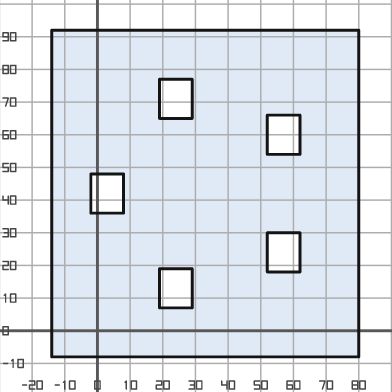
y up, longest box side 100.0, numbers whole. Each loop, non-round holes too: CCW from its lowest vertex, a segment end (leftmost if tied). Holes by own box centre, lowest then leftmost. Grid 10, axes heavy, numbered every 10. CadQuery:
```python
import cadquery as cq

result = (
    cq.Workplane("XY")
    .moveTo(-14.0, -8.0)
    .lineTo(80.0, -8.0)
    .lineTo(80.0, 92.0)
    .lineTo(-14.0, 92.0)
    .close()
    .moveTo(19.0, 7.0)
    .lineTo(29.0, 7.0)
    .lineTo(29.0, 19.0)
    .lineTo(19.0, 19.0)
    .close()
    .moveTo(52.0, 18.0)
    .lineTo(62.0, 18.0)
    .lineTo(62.0, 30.0)
    .lineTo(52.0, 30.0)
    .close()
    .moveTo(-2.0, 36.0)
    .lineTo(8.0, 36.0)
    .lineTo(8.0, 48.0)
    .lineTo(-2.0, 48.0)
    .close()
    .moveTo(52.0, 54.0)
    .lineTo(62.0, 54.0)
    .lineTo(62.0, 66.0)
    .lineTo(52.0, 66.0)
    .close()
    .moveTo(19.0, 65.0)
    .lineTo(29.0, 65.0)
    .lineTo(29.0, 77.0)
    .lineTo(19.0, 77.0)
    .close()
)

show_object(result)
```